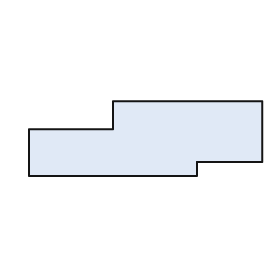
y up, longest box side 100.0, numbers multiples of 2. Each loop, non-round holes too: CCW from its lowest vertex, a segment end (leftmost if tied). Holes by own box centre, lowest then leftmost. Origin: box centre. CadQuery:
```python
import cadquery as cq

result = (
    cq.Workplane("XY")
    .moveTo(-50.0, -16.0)
    .lineTo(22.0, -16.0)
    .lineTo(22.0, -10.0)
    .lineTo(50.0, -10.0)
    .lineTo(50.0, 16.0)
    .lineTo(-14.0, 16.0)
    .lineTo(-14.0, 4.0)
    .lineTo(-50.0, 4.0)
    .close()
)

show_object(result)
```